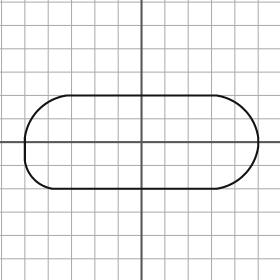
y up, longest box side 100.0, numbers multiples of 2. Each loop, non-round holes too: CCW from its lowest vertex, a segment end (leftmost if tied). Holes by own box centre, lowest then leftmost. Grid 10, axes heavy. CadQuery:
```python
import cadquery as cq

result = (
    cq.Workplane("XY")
    .moveTo(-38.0, -20.0)
    .lineTo(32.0, -20.0)
    .threePointArc((44.0, -14.0), (50.0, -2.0))
    .lineTo(50.0, 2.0)
    .threePointArc((44.0, 14.0), (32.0, 20.0))
    .lineTo(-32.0, 20.0)
    .threePointArc((-44.0, 14.0), (-50.0, 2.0))
    .lineTo(-50.0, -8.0)
    .threePointArc((-46.0, -16.0), (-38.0, -20.0))
    .close()
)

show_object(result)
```